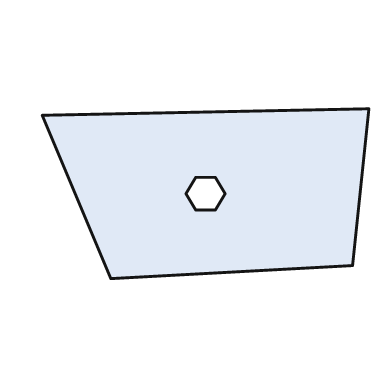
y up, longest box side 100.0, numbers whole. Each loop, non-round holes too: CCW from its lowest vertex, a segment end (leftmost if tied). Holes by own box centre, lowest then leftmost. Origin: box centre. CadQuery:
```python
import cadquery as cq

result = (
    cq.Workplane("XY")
    .moveTo(-29.0, -26.0)
    .lineTo(45.0, -22.0)
    .lineTo(50.0, 26.0)
    .lineTo(-50.0, 24.0)
    .close()
    .moveTo(-3.0, -5.0)
    .lineTo(3.0, -5.0)
    .lineTo(6.0, 0.0)
    .lineTo(3.0, 5.0)
    .lineTo(-3.0, 5.0)
    .lineTo(-6.0, 0.0)
    .close()
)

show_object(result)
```